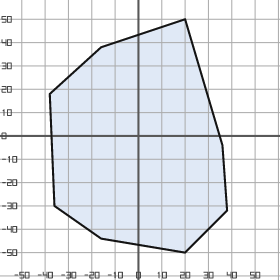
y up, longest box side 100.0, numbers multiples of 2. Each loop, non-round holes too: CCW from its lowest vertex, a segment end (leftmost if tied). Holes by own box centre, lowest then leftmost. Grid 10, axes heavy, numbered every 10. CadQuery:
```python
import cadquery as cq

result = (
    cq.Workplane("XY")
    .moveTo(20.0, -50.0)
    .lineTo(38.0, -32.0)
    .lineTo(36.0, -4.0)
    .lineTo(20.0, 50.0)
    .lineTo(-16.0, 38.0)
    .lineTo(-38.0, 18.0)
    .lineTo(-36.0, -30.0)
    .lineTo(-16.0, -44.0)
    .close()
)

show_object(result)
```